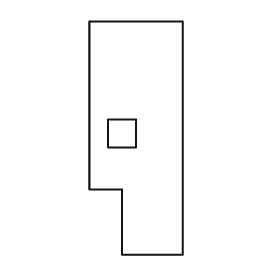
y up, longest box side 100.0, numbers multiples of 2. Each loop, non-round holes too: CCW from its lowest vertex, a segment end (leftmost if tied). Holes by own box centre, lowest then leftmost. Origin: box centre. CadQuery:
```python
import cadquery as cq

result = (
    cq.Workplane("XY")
    .moveTo(-6.0, -50.0)
    .lineTo(20.0, -50.0)
    .lineTo(20.0, 50.0)
    .lineTo(-20.0, 50.0)
    .lineTo(-20.0, -22.0)
    .lineTo(-6.0, -22.0)
    .close()
    .moveTo(-12.0, -4.0)
    .lineTo(0.0, -4.0)
    .lineTo(0.0, 8.0)
    .lineTo(-12.0, 8.0)
    .close()
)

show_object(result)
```